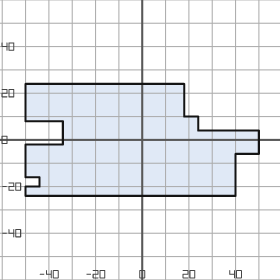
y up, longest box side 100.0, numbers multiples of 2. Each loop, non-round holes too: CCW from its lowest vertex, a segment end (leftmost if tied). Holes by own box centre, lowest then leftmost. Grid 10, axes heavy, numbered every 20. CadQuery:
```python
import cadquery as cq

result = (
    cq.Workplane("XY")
    .moveTo(-50.0, -24.0)
    .lineTo(40.0, -24.0)
    .lineTo(40.0, -6.0)
    .lineTo(50.0, -6.0)
    .lineTo(50.0, 4.0)
    .lineTo(24.0, 4.0)
    .lineTo(24.0, 10.0)
    .lineTo(18.0, 10.0)
    .lineTo(18.0, 24.0)
    .lineTo(-50.0, 24.0)
    .lineTo(-50.0, 8.0)
    .lineTo(-34.0, 8.0)
    .lineTo(-34.0, -2.0)
    .lineTo(-50.0, -2.0)
    .lineTo(-50.0, -16.0)
    .lineTo(-44.0, -16.0)
    .lineTo(-44.0, -20.0)
    .lineTo(-50.0, -20.0)
    .close()
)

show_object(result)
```